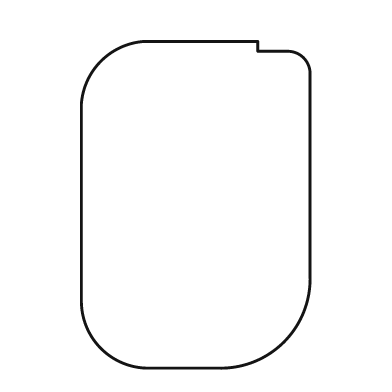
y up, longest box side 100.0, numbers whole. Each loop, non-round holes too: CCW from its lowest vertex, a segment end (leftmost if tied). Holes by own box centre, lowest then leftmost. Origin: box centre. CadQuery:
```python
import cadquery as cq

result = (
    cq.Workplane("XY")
    .moveTo(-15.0, -50.0)
    .lineTo(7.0, -50.0)
    .threePointArc((27.0, -42.0), (35.0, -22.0))
    .lineTo(35.0, 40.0)
    .threePointArc((33.0, 45.0), (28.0, 47.0))
    .lineTo(19.0, 47.0)
    .lineTo(19.0, 50.0)
    .lineTo(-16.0, 50.0)
    .threePointArc((-29.0, 44.0), (-35.0, 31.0))
    .lineTo(-35.0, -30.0)
    .threePointArc((-29.0, -44.0), (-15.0, -50.0))
    .close()
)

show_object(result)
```